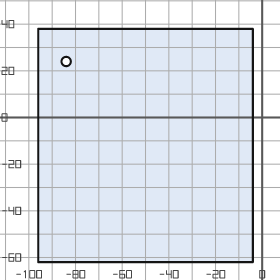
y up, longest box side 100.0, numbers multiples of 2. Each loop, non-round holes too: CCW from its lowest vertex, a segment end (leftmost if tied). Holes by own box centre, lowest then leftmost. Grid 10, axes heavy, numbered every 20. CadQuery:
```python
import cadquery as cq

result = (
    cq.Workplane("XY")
    .moveTo(-96.0, -62.0)
    .lineTo(-4.0, -62.0)
    .lineTo(-4.0, 38.0)
    .lineTo(-96.0, 38.0)
    .close()
    .moveTo(-84.0, 24.0)
    .circle(2.0)
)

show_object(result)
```